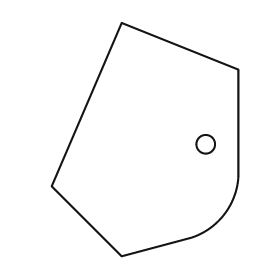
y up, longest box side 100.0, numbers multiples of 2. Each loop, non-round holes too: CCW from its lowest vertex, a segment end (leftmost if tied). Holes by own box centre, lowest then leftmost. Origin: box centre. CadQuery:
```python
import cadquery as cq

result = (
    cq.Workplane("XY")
    .moveTo(-10.0, -50.0)
    .lineTo(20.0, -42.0)
    .threePointArc((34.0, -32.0), (40.0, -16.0))
    .lineTo(40.0, 30.0)
    .lineTo(-10.0, 50.0)
    .lineTo(-40.0, -20.0)
    .close()
    .moveTo(26.0, -2.0)
    .circle(4.0)
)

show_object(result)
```